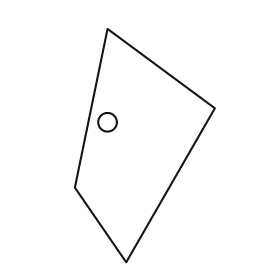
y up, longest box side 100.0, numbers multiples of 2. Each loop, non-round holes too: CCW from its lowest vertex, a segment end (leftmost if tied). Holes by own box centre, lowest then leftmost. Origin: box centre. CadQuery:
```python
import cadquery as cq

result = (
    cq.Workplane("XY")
    .moveTo(-8.0, -50.0)
    .lineTo(30.0, 16.0)
    .lineTo(-16.0, 50.0)
    .lineTo(-30.0, -18.0)
    .close()
    .moveTo(-16.0, 10.0)
    .circle(4.0)
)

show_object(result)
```